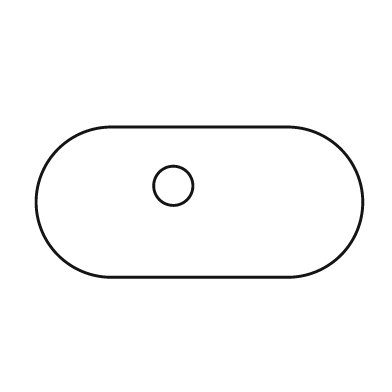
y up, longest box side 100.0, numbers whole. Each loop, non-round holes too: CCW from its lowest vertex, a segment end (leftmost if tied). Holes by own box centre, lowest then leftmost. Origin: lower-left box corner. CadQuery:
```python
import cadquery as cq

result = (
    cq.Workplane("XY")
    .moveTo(23.0, 0.0)
    .lineTo(77.0, 0.0)
    .threePointArc((100.0, 23.0), (77.0, 46.0))
    .lineTo(23.0, 46.0)
    .threePointArc((0.0, 23.0), (23.0, 0.0))
    .close()
    .moveTo(42.0, 28.0)
    .circle(6.0)
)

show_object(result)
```